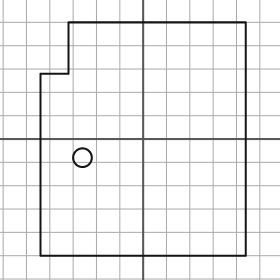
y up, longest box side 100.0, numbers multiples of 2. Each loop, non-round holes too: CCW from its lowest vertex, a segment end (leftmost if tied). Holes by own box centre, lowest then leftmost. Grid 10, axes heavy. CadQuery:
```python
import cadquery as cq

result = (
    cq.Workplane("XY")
    .moveTo(-44.0, -50.0)
    .lineTo(44.0, -50.0)
    .lineTo(44.0, 50.0)
    .lineTo(-32.0, 50.0)
    .lineTo(-32.0, 28.0)
    .lineTo(-44.0, 28.0)
    .close()
    .moveTo(-26.0, -8.0)
    .circle(4.0)
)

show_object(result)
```